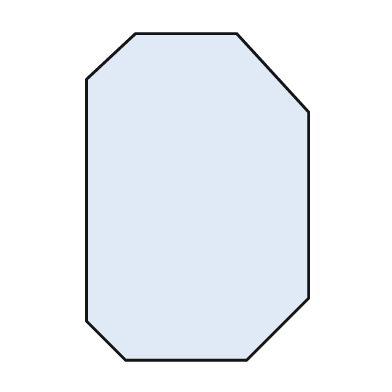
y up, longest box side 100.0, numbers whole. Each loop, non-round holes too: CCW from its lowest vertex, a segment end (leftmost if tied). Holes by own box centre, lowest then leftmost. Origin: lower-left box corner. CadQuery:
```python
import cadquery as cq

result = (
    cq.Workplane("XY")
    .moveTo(12.0, 0.0)
    .lineTo(49.0, 0.0)
    .lineTo(68.0, 19.0)
    .lineTo(68.0, 76.0)
    .lineTo(46.0, 100.0)
    .lineTo(15.0, 100.0)
    .lineTo(0.0, 86.0)
    .lineTo(0.0, 12.0)
    .close()
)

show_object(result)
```